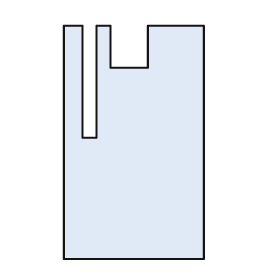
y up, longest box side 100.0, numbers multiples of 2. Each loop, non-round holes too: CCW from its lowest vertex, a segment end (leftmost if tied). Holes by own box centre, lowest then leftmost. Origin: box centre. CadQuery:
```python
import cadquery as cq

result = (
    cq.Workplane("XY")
    .moveTo(-30.0, -50.0)
    .lineTo(30.0, -50.0)
    .lineTo(30.0, 50.0)
    .lineTo(6.0, 50.0)
    .lineTo(6.0, 32.0)
    .lineTo(-10.0, 32.0)
    .lineTo(-10.0, 50.0)
    .lineTo(-16.0, 50.0)
    .lineTo(-16.0, 2.0)
    .lineTo(-22.0, 2.0)
    .lineTo(-22.0, 50.0)
    .lineTo(-30.0, 50.0)
    .close()
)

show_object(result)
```